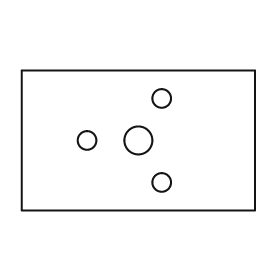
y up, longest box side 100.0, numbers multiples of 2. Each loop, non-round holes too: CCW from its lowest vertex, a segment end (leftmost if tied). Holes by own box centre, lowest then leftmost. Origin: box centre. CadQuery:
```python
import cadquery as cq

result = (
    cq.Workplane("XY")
    .moveTo(-50.0, -30.0)
    .lineTo(50.0, -30.0)
    .lineTo(50.0, 30.0)
    .lineTo(-50.0, 30.0)
    .close()
    .moveTo(10.0, -18.0)
    .circle(4.0)
    .moveTo(-22.0, 0.0)
    .circle(4.0)
    .moveTo(0.0, 0.0)
    .circle(6.0)
    .moveTo(10.0, 18.0)
    .circle(4.0)
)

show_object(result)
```